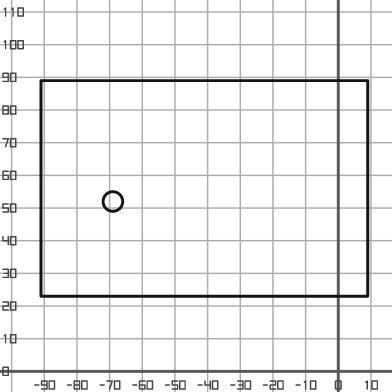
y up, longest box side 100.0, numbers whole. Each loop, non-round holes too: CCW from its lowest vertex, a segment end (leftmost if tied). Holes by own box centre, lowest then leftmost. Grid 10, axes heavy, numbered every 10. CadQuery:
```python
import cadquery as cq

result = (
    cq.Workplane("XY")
    .moveTo(-91.0, 23.0)
    .lineTo(9.0, 23.0)
    .lineTo(9.0, 89.0)
    .lineTo(-91.0, 89.0)
    .close()
    .moveTo(-69.0, 52.0)
    .circle(3.0)
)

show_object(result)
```